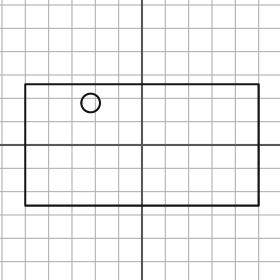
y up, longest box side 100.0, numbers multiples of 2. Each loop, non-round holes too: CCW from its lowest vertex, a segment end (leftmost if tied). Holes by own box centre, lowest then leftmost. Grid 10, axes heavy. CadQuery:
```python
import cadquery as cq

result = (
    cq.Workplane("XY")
    .moveTo(-50.0, -26.0)
    .lineTo(50.0, -26.0)
    .lineTo(50.0, 26.0)
    .lineTo(-50.0, 26.0)
    .close()
    .moveTo(-22.0, 18.0)
    .circle(4.0)
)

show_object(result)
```